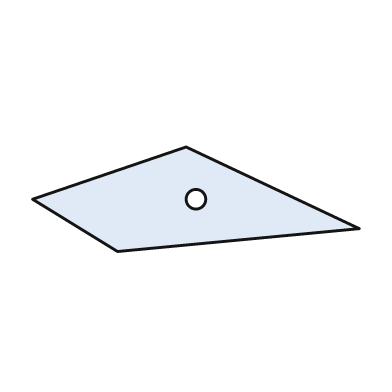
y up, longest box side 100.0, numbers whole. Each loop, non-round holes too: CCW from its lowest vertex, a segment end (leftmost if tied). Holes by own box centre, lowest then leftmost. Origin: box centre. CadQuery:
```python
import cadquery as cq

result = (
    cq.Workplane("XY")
    .moveTo(-24.0, -16.0)
    .lineTo(50.0, -9.0)
    .lineTo(-3.0, 16.0)
    .lineTo(-50.0, 0.0)
    .close()
    .moveTo(0.0, 0.0)
    .circle(3.0)
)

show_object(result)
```